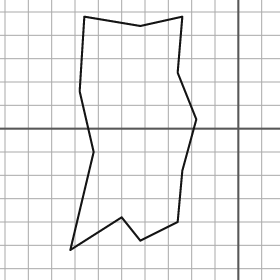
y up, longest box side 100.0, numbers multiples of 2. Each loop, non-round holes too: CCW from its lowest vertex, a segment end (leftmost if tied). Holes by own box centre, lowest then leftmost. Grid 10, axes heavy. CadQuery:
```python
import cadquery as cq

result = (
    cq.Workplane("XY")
    .moveTo(-72.0, -52.0)
    .lineTo(-50.0, -38.0)
    .lineTo(-42.0, -48.0)
    .lineTo(-26.0, -40.0)
    .lineTo(-24.0, -18.0)
    .lineTo(-18.0, 4.0)
    .lineTo(-26.0, 24.0)
    .lineTo(-24.0, 48.0)
    .lineTo(-42.0, 44.0)
    .lineTo(-66.0, 48.0)
    .lineTo(-68.0, 16.0)
    .lineTo(-62.0, -10.0)
    .close()
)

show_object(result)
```